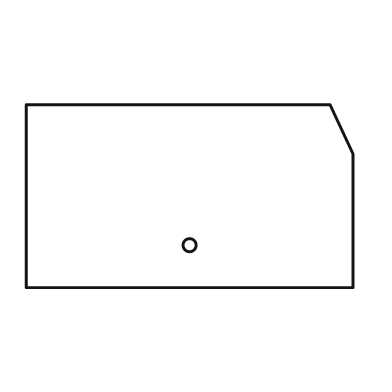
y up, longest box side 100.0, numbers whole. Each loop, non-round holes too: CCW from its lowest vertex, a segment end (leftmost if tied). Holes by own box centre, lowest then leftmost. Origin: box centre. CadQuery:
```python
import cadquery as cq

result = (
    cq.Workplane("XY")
    .moveTo(-50.0, -28.0)
    .lineTo(50.0, -28.0)
    .lineTo(50.0, 13.0)
    .lineTo(43.0, 28.0)
    .lineTo(-50.0, 28.0)
    .close()
    .moveTo(0.0, -15.0)
    .circle(2.0)
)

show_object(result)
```